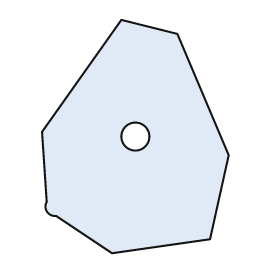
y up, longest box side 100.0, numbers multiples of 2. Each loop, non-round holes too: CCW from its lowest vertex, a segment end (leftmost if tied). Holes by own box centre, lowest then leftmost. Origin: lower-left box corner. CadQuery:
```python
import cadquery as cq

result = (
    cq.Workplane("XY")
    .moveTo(30.0, 0.0)
    .lineTo(72.0, 6.0)
    .lineTo(80.0, 42.0)
    .lineTo(58.0, 94.0)
    .lineTo(34.0, 100.0)
    .lineTo(0.0, 52.0)
    .lineTo(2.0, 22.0)
    .threePointArc((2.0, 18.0), (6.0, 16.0))
    .close()
    .moveTo(40.0, 50.0)
    .circle(6.0)
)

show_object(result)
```